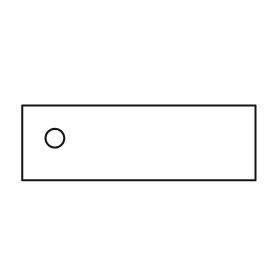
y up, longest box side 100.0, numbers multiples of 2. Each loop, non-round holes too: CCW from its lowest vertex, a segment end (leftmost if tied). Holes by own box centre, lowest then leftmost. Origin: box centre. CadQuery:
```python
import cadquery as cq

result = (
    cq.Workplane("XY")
    .moveTo(-50.0, -16.0)
    .lineTo(50.0, -16.0)
    .lineTo(50.0, 16.0)
    .lineTo(-50.0, 16.0)
    .close()
    .moveTo(-36.0, 2.0)
    .circle(4.0)
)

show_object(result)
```